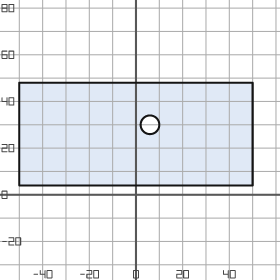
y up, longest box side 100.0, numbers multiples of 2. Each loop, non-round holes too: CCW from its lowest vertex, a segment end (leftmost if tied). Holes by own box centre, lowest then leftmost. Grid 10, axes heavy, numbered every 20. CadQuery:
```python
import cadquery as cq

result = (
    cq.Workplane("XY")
    .moveTo(-50.0, 4.0)
    .lineTo(50.0, 4.0)
    .lineTo(50.0, 48.0)
    .lineTo(-50.0, 48.0)
    .close()
    .moveTo(6.0, 30.0)
    .circle(4.0)
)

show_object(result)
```